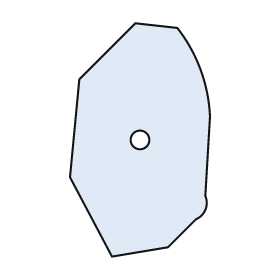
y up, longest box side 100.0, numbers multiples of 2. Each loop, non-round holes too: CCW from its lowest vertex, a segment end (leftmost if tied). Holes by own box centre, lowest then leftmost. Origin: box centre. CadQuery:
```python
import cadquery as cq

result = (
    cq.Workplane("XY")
    .moveTo(-12.0, -50.0)
    .lineTo(12.0, -46.0)
    .lineTo(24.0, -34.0)
    .threePointArc((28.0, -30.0), (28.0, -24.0))
    .lineTo(30.0, 10.0)
    .threePointArc((26.0, 30.0), (16.0, 48.0))
    .lineTo(-2.0, 50.0)
    .lineTo(-26.0, 26.0)
    .lineTo(-30.0, -16.0)
    .close()
    .moveTo(0.0, 0.0)
    .circle(4.0)
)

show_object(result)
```